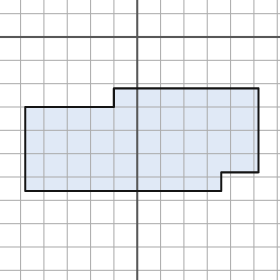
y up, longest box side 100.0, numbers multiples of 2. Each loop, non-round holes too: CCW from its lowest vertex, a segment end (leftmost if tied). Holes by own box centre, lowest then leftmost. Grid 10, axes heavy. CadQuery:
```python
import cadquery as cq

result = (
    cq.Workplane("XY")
    .moveTo(-48.0, -66.0)
    .lineTo(36.0, -66.0)
    .lineTo(36.0, -58.0)
    .lineTo(52.0, -58.0)
    .lineTo(52.0, -22.0)
    .lineTo(-10.0, -22.0)
    .lineTo(-10.0, -30.0)
    .lineTo(-48.0, -30.0)
    .close()
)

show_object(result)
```